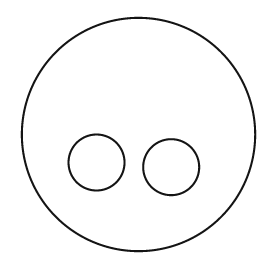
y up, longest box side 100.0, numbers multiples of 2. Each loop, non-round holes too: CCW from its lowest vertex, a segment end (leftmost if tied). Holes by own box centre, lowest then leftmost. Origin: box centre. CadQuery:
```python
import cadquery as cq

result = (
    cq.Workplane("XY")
    .moveTo(0.0, 0.0)
    .circle(50.0)
    .moveTo(14.0, -14.0)
    .circle(12.0)
    .moveTo(-18.0, -12.0)
    .circle(12.0)
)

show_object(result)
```